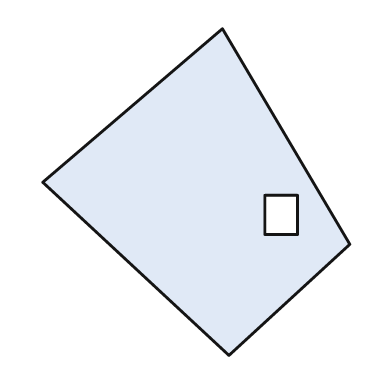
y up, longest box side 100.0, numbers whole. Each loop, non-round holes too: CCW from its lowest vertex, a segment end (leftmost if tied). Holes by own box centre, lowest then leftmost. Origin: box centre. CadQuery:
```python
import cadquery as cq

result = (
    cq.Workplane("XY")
    .moveTo(10.0, -50.0)
    .lineTo(47.0, -16.0)
    .lineTo(8.0, 50.0)
    .lineTo(-47.0, 3.0)
    .close()
    .moveTo(21.0, -13.0)
    .lineTo(31.0, -13.0)
    .lineTo(31.0, -1.0)
    .lineTo(21.0, -1.0)
    .close()
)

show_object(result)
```